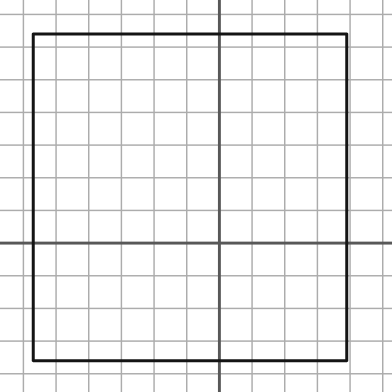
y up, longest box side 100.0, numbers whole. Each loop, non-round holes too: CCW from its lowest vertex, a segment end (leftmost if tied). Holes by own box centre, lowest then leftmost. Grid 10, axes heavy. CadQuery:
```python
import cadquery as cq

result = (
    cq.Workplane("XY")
    .moveTo(-57.0, -36.0)
    .lineTo(39.0, -36.0)
    .lineTo(39.0, 64.0)
    .lineTo(-57.0, 64.0)
    .close()
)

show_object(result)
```